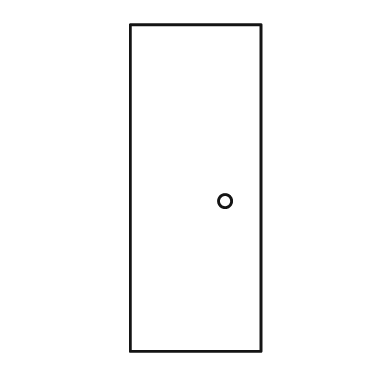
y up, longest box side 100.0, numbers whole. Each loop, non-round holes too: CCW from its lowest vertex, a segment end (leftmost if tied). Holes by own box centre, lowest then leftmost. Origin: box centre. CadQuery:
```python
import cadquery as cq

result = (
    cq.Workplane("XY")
    .moveTo(-20.0, -50.0)
    .lineTo(20.0, -50.0)
    .lineTo(20.0, 50.0)
    .lineTo(-20.0, 50.0)
    .close()
    .moveTo(9.0, -4.0)
    .circle(2.0)
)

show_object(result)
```